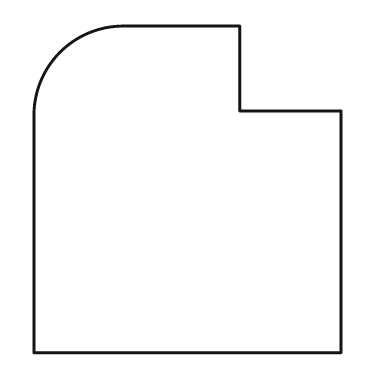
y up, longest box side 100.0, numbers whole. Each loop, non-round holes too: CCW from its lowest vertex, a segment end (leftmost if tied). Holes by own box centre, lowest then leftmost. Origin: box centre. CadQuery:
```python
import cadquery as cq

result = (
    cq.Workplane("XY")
    .moveTo(-47.0, -50.0)
    .lineTo(47.0, -50.0)
    .lineTo(47.0, 24.0)
    .lineTo(16.0, 24.0)
    .lineTo(16.0, 50.0)
    .lineTo(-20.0, 50.0)
    .threePointArc((-39.0, 42.0), (-47.0, 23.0))
    .close()
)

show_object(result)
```